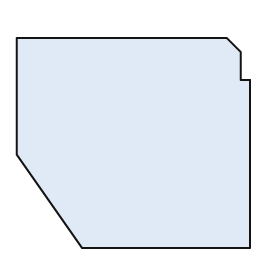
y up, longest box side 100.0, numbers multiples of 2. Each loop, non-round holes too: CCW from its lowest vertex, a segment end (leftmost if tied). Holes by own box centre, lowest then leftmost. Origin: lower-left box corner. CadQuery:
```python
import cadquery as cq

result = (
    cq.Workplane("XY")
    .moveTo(28.0, 0.0)
    .lineTo(100.0, 0.0)
    .lineTo(100.0, 72.0)
    .lineTo(96.0, 72.0)
    .lineTo(96.0, 84.0)
    .lineTo(90.0, 90.0)
    .lineTo(0.0, 90.0)
    .lineTo(0.0, 40.0)
    .close()
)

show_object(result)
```